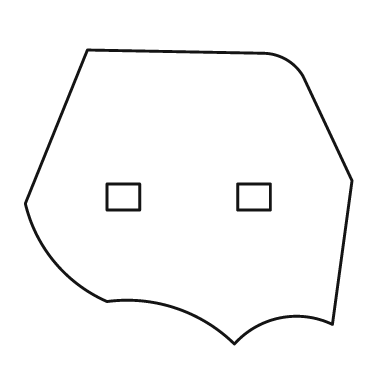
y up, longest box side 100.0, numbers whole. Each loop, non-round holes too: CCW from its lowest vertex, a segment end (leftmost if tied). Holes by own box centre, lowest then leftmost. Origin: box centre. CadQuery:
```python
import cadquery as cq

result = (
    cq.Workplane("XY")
    .moveTo(14.0, -45.0)
    .threePointArc((28.0, -37.0), (44.0, -39.0))
    .lineTo(50.0, 5.0)
    .lineTo(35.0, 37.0)
    .threePointArc((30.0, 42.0), (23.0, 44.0))
    .lineTo(-31.0, 45.0)
    .lineTo(-50.0, -2.0)
    .threePointArc((-41.0, -20.0), (-25.0, -32.0))
    .threePointArc((-4.0, -34.0), (14.0, -45.0))
    .close()
    .moveTo(-25.0, -4.0)
    .lineTo(-15.0, -4.0)
    .lineTo(-15.0, 4.0)
    .lineTo(-25.0, 4.0)
    .close()
    .moveTo(15.0, -4.0)
    .lineTo(25.0, -4.0)
    .lineTo(25.0, 4.0)
    .lineTo(15.0, 4.0)
    .close()
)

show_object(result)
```